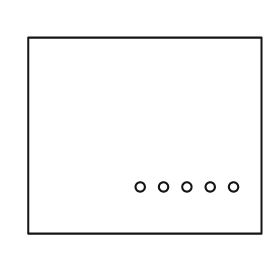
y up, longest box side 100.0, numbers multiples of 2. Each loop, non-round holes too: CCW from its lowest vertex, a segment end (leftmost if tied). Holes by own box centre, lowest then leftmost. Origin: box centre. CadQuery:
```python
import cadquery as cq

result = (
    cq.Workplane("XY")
    .moveTo(-50.0, -42.0)
    .lineTo(50.0, -42.0)
    .lineTo(50.0, 42.0)
    .lineTo(-50.0, 42.0)
    .close()
    .moveTo(-2.0, -22.0)
    .circle(2.0)
    .moveTo(8.0, -22.0)
    .circle(2.0)
    .moveTo(18.0, -22.0)
    .circle(2.0)
    .moveTo(28.0, -22.0)
    .circle(2.0)
    .moveTo(38.0, -22.0)
    .circle(2.0)
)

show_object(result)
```